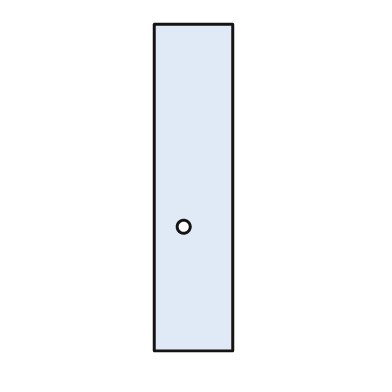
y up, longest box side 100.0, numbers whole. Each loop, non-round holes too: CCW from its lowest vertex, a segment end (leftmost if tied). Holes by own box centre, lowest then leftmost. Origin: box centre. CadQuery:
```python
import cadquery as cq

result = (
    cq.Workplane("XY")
    .moveTo(-12.0, -50.0)
    .lineTo(12.0, -50.0)
    .lineTo(12.0, 50.0)
    .lineTo(-12.0, 50.0)
    .close()
    .moveTo(-3.0, -12.0)
    .circle(2.0)
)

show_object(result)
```